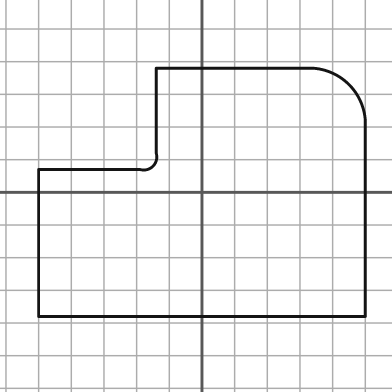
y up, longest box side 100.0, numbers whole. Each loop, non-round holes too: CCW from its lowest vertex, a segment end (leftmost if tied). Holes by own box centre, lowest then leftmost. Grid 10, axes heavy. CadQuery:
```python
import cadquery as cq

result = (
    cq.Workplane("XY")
    .moveTo(-50.0, -38.0)
    .lineTo(50.0, -38.0)
    .lineTo(50.0, 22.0)
    .threePointArc((45.0, 33.0), (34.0, 38.0))
    .lineTo(-14.0, 38.0)
    .lineTo(-14.0, 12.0)
    .threePointArc((-15.0, 8.0), (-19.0, 7.0))
    .lineTo(-50.0, 7.0)
    .close()
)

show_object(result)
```